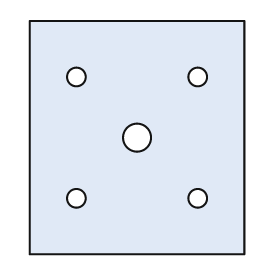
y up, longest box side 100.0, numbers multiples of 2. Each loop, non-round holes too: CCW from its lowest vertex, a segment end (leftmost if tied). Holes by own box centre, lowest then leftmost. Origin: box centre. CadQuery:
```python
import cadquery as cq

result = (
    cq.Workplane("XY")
    .moveTo(-46.0, -50.0)
    .lineTo(46.0, -50.0)
    .lineTo(46.0, 50.0)
    .lineTo(-46.0, 50.0)
    .close()
    .moveTo(-26.0, -26.0)
    .circle(4.0)
    .moveTo(26.0, -26.0)
    .circle(4.0)
    .moveTo(0.0, 0.0)
    .circle(6.0)
    .moveTo(-26.0, 26.0)
    .circle(4.0)
    .moveTo(26.0, 26.0)
    .circle(4.0)
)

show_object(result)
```